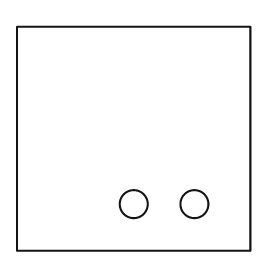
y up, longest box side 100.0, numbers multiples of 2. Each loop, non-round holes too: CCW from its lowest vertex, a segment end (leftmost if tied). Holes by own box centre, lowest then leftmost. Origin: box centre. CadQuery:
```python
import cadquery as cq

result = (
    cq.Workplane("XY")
    .moveTo(-50.0, -48.0)
    .lineTo(50.0, -48.0)
    .lineTo(50.0, 48.0)
    .lineTo(-50.0, 48.0)
    .close()
    .moveTo(0.0, -28.0)
    .circle(6.0)
    .moveTo(26.0, -28.0)
    .circle(6.0)
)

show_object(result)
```